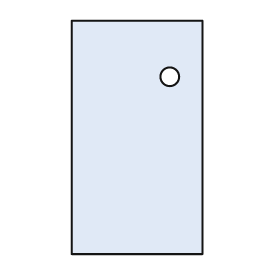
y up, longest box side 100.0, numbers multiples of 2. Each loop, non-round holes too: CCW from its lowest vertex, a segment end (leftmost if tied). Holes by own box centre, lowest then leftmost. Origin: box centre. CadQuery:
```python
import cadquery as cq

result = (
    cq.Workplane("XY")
    .moveTo(-28.0, -50.0)
    .lineTo(28.0, -50.0)
    .lineTo(28.0, 50.0)
    .lineTo(-28.0, 50.0)
    .close()
    .moveTo(14.0, 26.0)
    .circle(4.0)
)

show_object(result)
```